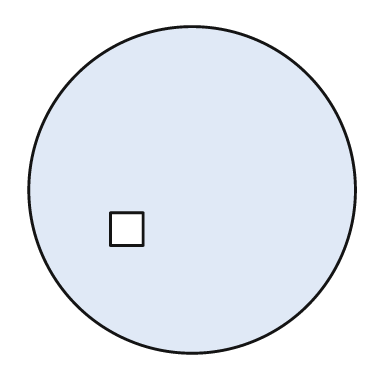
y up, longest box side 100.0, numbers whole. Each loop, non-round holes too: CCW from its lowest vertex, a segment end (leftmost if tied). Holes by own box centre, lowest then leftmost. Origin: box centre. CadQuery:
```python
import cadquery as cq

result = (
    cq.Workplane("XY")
    .moveTo(0.0, 0.0)
    .circle(50.0)
    .moveTo(-25.0, -17.0)
    .lineTo(-15.0, -17.0)
    .lineTo(-15.0, -7.0)
    .lineTo(-25.0, -7.0)
    .close()
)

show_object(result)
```